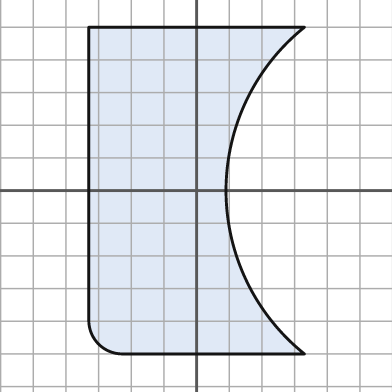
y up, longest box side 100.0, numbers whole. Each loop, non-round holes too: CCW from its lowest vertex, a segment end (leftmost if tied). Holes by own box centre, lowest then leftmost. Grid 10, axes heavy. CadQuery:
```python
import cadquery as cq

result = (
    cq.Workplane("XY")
    .moveTo(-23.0, -50.0)
    .lineTo(33.0, -50.0)
    .threePointArc((9.0, 0.0), (33.0, 50.0))
    .lineTo(-33.0, 50.0)
    .lineTo(-33.0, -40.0)
    .threePointArc((-30.0, -47.0), (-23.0, -50.0))
    .close()
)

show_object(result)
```